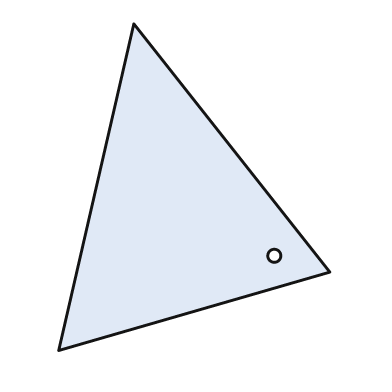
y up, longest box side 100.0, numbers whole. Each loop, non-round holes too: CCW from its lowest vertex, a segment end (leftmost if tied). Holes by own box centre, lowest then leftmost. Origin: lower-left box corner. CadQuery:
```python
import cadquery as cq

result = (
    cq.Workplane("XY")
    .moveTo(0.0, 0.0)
    .lineTo(83.0, 24.0)
    .lineTo(23.0, 100.0)
    .close()
    .moveTo(66.0, 29.0)
    .circle(2.0)
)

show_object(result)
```